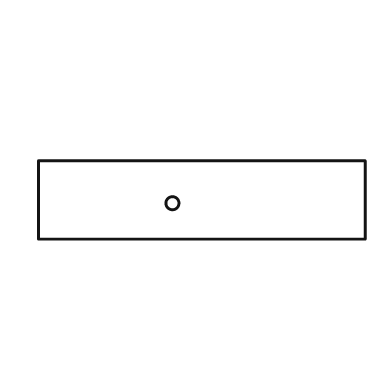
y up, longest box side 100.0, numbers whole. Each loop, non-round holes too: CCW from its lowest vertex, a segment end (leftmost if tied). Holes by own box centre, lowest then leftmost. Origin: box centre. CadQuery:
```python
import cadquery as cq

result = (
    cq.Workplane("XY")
    .moveTo(-50.0, -12.0)
    .lineTo(50.0, -12.0)
    .lineTo(50.0, 12.0)
    .lineTo(-50.0, 12.0)
    .close()
    .moveTo(-9.0, -1.0)
    .circle(2.0)
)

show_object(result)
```